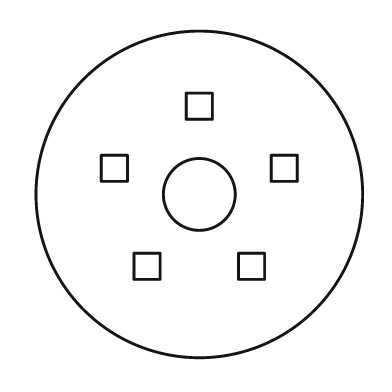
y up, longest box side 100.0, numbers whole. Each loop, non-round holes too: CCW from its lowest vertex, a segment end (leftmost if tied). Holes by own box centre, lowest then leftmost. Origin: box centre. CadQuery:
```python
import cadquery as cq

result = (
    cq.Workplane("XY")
    .moveTo(0.0, 0.0)
    .circle(50.0)
    .moveTo(-20.0, -26.0)
    .lineTo(-12.0, -26.0)
    .lineTo(-12.0, -18.0)
    .lineTo(-20.0, -18.0)
    .close()
    .moveTo(12.0, -26.0)
    .lineTo(20.0, -26.0)
    .lineTo(20.0, -18.0)
    .lineTo(12.0, -18.0)
    .close()
    .moveTo(0.0, 0.0)
    .circle(11.0)
    .moveTo(-30.0, 4.0)
    .lineTo(-22.0, 4.0)
    .lineTo(-22.0, 12.0)
    .lineTo(-30.0, 12.0)
    .close()
    .moveTo(22.0, 4.0)
    .lineTo(30.0, 4.0)
    .lineTo(30.0, 12.0)
    .lineTo(22.0, 12.0)
    .close()
    .moveTo(-4.0, 23.0)
    .lineTo(4.0, 23.0)
    .lineTo(4.0, 31.0)
    .lineTo(-4.0, 31.0)
    .close()
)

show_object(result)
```